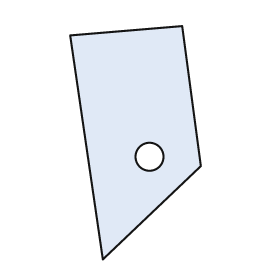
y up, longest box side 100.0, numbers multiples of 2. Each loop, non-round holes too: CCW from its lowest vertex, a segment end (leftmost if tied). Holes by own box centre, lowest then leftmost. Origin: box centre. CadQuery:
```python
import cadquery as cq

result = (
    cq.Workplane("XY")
    .moveTo(-14.0, -50.0)
    .lineTo(28.0, -10.0)
    .lineTo(20.0, 50.0)
    .lineTo(-28.0, 46.0)
    .close()
    .moveTo(6.0, -6.0)
    .circle(6.0)
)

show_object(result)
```